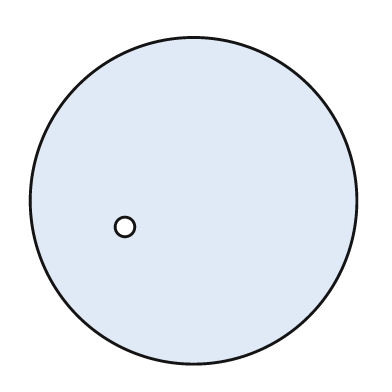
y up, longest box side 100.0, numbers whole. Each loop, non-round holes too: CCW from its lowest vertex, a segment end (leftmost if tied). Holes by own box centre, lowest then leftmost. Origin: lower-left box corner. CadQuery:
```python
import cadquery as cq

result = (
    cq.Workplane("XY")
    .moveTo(50.0, 50.0)
    .circle(50.0)
    .moveTo(29.0, 42.0)
    .circle(3.0)
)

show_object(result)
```